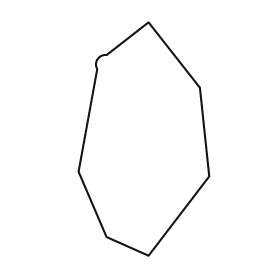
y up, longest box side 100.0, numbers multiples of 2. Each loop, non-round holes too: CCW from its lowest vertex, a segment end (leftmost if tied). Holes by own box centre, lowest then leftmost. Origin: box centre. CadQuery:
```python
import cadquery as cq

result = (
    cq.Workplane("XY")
    .moveTo(2.0, -50.0)
    .lineTo(28.0, -16.0)
    .lineTo(24.0, 22.0)
    .lineTo(2.0, 50.0)
    .lineTo(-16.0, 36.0)
    .threePointArc((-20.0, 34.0), (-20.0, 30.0))
    .lineTo(-28.0, -14.0)
    .lineTo(-16.0, -42.0)
    .close()
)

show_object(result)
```